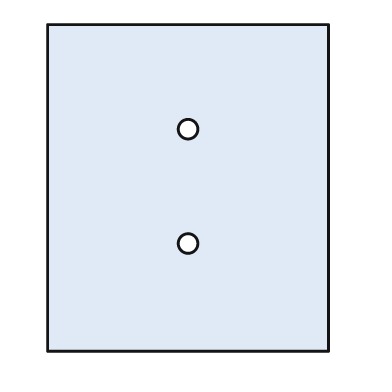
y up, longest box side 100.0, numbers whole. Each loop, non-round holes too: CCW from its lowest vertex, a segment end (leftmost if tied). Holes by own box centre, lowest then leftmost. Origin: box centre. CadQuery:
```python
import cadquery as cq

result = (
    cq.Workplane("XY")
    .moveTo(-43.0, -50.0)
    .lineTo(43.0, -50.0)
    .lineTo(43.0, 50.0)
    .lineTo(-43.0, 50.0)
    .close()
    .moveTo(0.0, -17.0)
    .circle(3.0)
    .moveTo(0.0, 18.0)
    .circle(3.0)
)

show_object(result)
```